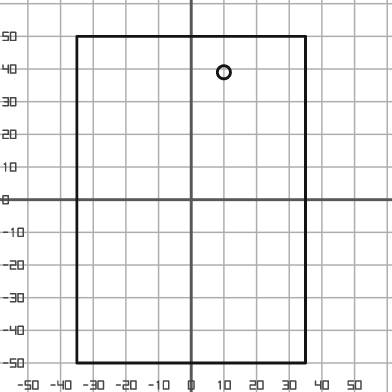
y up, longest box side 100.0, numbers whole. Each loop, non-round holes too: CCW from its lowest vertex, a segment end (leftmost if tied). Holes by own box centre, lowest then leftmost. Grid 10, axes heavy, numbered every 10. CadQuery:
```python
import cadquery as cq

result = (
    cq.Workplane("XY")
    .moveTo(-35.0, -50.0)
    .lineTo(35.0, -50.0)
    .lineTo(35.0, 50.0)
    .lineTo(-35.0, 50.0)
    .close()
    .moveTo(10.0, 39.0)
    .circle(2.0)
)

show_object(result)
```